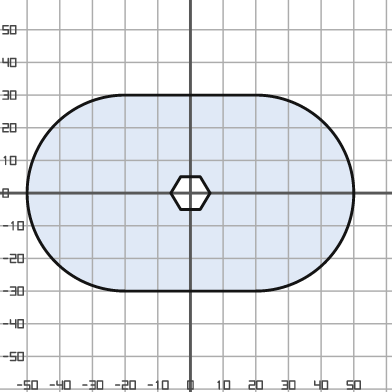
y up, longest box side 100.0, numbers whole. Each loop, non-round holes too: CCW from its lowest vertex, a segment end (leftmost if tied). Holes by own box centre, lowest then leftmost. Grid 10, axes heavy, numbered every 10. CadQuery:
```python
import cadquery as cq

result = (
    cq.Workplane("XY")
    .moveTo(-20.0, -30.0)
    .lineTo(20.0, -30.0)
    .threePointArc((50.0, 0.0), (20.0, 30.0))
    .lineTo(-20.0, 30.0)
    .threePointArc((-50.0, 0.0), (-20.0, -30.0))
    .close()
    .moveTo(-3.0, -5.0)
    .lineTo(3.0, -5.0)
    .lineTo(6.0, 0.0)
    .lineTo(3.0, 5.0)
    .lineTo(-3.0, 5.0)
    .lineTo(-6.0, 0.0)
    .close()
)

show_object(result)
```